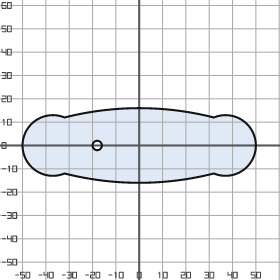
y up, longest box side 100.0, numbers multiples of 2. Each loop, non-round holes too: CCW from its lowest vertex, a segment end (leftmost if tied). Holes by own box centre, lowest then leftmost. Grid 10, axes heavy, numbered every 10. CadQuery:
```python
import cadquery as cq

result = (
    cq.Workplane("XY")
    .moveTo(-32.0, -12.0)
    .threePointArc((0.0, -16.0), (32.0, -12.0))
    .threePointArc((50.0, 0.0), (32.0, 12.0))
    .threePointArc((0.0, 16.0), (-32.0, 12.0))
    .threePointArc((-50.0, 0.0), (-32.0, -12.0))
    .close()
    .moveTo(-18.0, 0.0)
    .circle(2.0)
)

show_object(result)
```